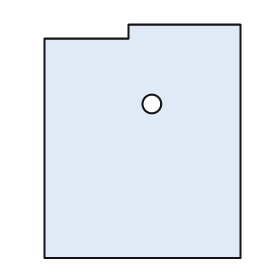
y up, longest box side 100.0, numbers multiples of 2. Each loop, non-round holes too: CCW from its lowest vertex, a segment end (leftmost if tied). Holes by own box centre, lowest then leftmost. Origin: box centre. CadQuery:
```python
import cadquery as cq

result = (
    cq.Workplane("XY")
    .moveTo(-42.0, -50.0)
    .lineTo(42.0, -50.0)
    .lineTo(42.0, 50.0)
    .lineTo(-6.0, 50.0)
    .lineTo(-6.0, 44.0)
    .lineTo(-42.0, 44.0)
    .close()
    .moveTo(4.0, 16.0)
    .circle(4.0)
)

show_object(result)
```